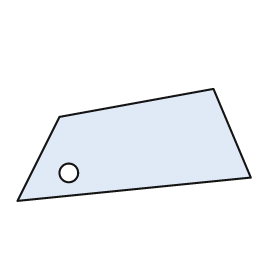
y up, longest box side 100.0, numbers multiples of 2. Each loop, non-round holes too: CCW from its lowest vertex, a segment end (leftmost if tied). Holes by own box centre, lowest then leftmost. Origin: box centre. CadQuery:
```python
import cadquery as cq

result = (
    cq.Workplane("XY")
    .moveTo(-50.0, -24.0)
    .lineTo(50.0, -14.0)
    .lineTo(34.0, 24.0)
    .lineTo(-32.0, 12.0)
    .close()
    .moveTo(-28.0, -12.0)
    .circle(4.0)
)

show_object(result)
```